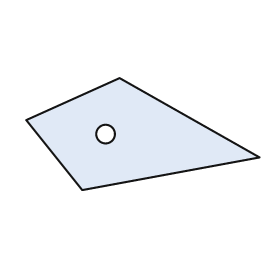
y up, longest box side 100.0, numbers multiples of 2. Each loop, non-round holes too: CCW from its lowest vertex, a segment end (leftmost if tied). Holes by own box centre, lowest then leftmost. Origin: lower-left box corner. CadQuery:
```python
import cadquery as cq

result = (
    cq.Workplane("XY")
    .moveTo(24.0, 0.0)
    .lineTo(100.0, 14.0)
    .lineTo(40.0, 48.0)
    .lineTo(0.0, 30.0)
    .close()
    .moveTo(34.0, 24.0)
    .circle(4.0)
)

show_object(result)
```